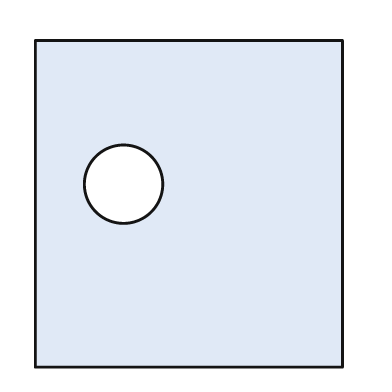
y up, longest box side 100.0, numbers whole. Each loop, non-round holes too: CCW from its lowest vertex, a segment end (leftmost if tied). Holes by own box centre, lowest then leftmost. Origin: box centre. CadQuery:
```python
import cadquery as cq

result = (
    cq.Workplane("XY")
    .moveTo(-47.0, -50.0)
    .lineTo(47.0, -50.0)
    .lineTo(47.0, 50.0)
    .lineTo(-47.0, 50.0)
    .close()
    .moveTo(-20.0, 6.0)
    .circle(12.0)
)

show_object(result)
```